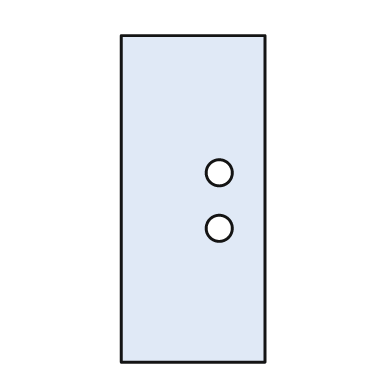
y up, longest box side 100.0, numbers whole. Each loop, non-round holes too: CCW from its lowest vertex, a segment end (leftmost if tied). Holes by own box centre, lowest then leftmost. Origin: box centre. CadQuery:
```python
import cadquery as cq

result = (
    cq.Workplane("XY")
    .moveTo(-22.0, -50.0)
    .lineTo(22.0, -50.0)
    .lineTo(22.0, 50.0)
    .lineTo(-22.0, 50.0)
    .close()
    .moveTo(8.0, -9.0)
    .circle(4.0)
    .moveTo(8.0, 8.0)
    .circle(4.0)
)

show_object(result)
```